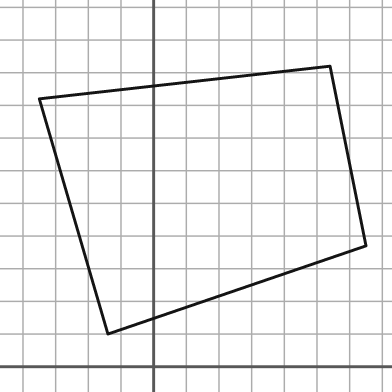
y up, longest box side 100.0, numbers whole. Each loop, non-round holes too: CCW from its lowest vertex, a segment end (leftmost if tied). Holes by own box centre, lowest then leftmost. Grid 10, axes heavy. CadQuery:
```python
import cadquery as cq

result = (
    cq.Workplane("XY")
    .moveTo(-14.0, 10.0)
    .lineTo(65.0, 37.0)
    .lineTo(54.0, 92.0)
    .lineTo(-35.0, 82.0)
    .close()
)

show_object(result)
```